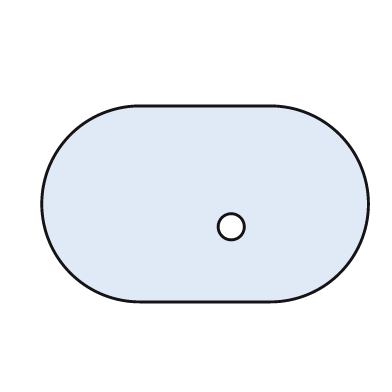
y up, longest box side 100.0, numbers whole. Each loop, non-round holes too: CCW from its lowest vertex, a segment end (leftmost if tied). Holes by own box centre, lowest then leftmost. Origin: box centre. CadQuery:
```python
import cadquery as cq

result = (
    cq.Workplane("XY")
    .moveTo(-20.0, -30.0)
    .lineTo(20.0, -30.0)
    .threePointArc((50.0, 0.0), (20.0, 30.0))
    .lineTo(-20.0, 30.0)
    .threePointArc((-50.0, 0.0), (-20.0, -30.0))
    .close()
    .moveTo(8.0, -7.0)
    .circle(4.0)
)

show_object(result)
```